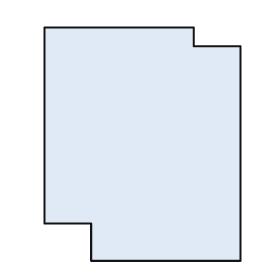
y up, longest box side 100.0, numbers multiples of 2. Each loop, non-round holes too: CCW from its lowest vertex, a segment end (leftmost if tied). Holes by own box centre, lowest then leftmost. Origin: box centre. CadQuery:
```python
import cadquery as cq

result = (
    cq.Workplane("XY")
    .moveTo(-22.0, -50.0)
    .lineTo(42.0, -50.0)
    .lineTo(42.0, 42.0)
    .lineTo(22.0, 42.0)
    .lineTo(22.0, 50.0)
    .lineTo(-42.0, 50.0)
    .lineTo(-42.0, -34.0)
    .lineTo(-22.0, -34.0)
    .close()
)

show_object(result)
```